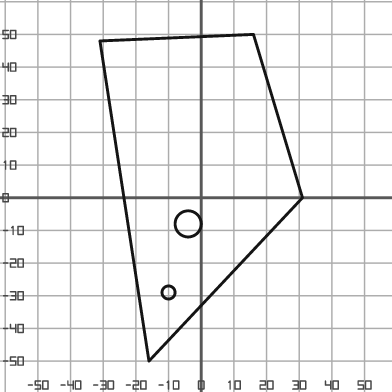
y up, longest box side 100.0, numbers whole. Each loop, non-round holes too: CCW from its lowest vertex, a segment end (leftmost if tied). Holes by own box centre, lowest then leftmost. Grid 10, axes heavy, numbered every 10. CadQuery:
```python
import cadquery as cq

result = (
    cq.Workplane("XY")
    .moveTo(-16.0, -50.0)
    .lineTo(31.0, 0.0)
    .lineTo(16.0, 50.0)
    .lineTo(-31.0, 48.0)
    .close()
    .moveTo(-10.0, -29.0)
    .circle(2.0)
    .moveTo(-4.0, -8.0)
    .circle(4.0)
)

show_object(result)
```